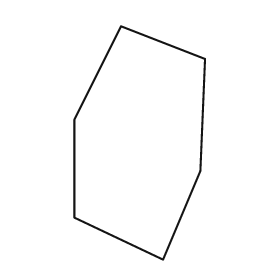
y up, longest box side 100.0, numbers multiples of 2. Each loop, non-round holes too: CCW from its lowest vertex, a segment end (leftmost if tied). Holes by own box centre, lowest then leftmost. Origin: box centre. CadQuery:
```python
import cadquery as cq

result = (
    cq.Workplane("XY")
    .moveTo(10.0, -50.0)
    .lineTo(26.0, -12.0)
    .lineTo(28.0, 36.0)
    .lineTo(-8.0, 50.0)
    .lineTo(-28.0, 10.0)
    .lineTo(-28.0, -32.0)
    .close()
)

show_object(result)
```